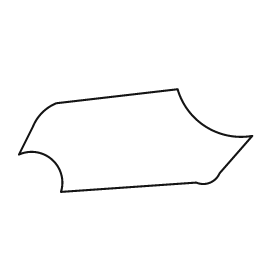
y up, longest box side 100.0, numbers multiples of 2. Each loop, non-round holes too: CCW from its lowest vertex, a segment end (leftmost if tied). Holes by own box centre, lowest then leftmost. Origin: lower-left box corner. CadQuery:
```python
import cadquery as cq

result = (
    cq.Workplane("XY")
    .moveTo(18.0, 0.0)
    .lineTo(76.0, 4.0)
    .threePointArc((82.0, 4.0), (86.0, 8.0))
    .lineTo(100.0, 24.0)
    .threePointArc((80.0, 28.0), (68.0, 44.0))
    .lineTo(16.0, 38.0)
    .threePointArc((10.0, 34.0), (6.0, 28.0))
    .lineTo(0.0, 16.0)
    .threePointArc((14.0, 14.0), (18.0, 0.0))
    .close()
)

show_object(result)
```